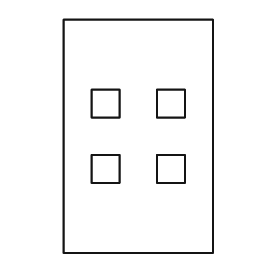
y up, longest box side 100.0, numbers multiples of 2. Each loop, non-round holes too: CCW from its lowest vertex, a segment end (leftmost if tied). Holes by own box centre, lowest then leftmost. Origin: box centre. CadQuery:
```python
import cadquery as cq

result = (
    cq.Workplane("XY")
    .moveTo(-32.0, -50.0)
    .lineTo(32.0, -50.0)
    .lineTo(32.0, 50.0)
    .lineTo(-32.0, 50.0)
    .close()
    .moveTo(-20.0, -20.0)
    .lineTo(-8.0, -20.0)
    .lineTo(-8.0, -8.0)
    .lineTo(-20.0, -8.0)
    .close()
    .moveTo(8.0, -20.0)
    .lineTo(20.0, -20.0)
    .lineTo(20.0, -8.0)
    .lineTo(8.0, -8.0)
    .close()
    .moveTo(-20.0, 8.0)
    .lineTo(-8.0, 8.0)
    .lineTo(-8.0, 20.0)
    .lineTo(-20.0, 20.0)
    .close()
    .moveTo(8.0, 8.0)
    .lineTo(20.0, 8.0)
    .lineTo(20.0, 20.0)
    .lineTo(8.0, 20.0)
    .close()
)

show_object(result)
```